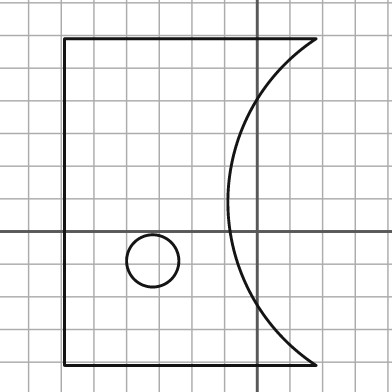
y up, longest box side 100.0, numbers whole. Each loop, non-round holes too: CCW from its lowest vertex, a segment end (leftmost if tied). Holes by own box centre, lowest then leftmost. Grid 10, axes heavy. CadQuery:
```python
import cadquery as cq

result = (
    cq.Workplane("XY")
    .moveTo(-59.0, -41.0)
    .lineTo(18.0, -41.0)
    .threePointArc((-9.0, 9.0), (18.0, 59.0))
    .lineTo(-59.0, 59.0)
    .close()
    .moveTo(-32.0, -9.0)
    .circle(8.0)
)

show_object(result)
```